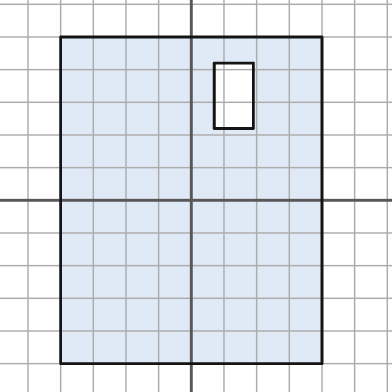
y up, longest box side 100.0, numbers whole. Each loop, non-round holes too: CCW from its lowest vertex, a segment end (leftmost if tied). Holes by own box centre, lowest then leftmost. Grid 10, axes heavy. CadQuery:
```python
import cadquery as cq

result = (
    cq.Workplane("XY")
    .moveTo(-40.0, -50.0)
    .lineTo(40.0, -50.0)
    .lineTo(40.0, 50.0)
    .lineTo(-40.0, 50.0)
    .close()
    .moveTo(7.0, 22.0)
    .lineTo(19.0, 22.0)
    .lineTo(19.0, 42.0)
    .lineTo(7.0, 42.0)
    .close()
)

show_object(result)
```